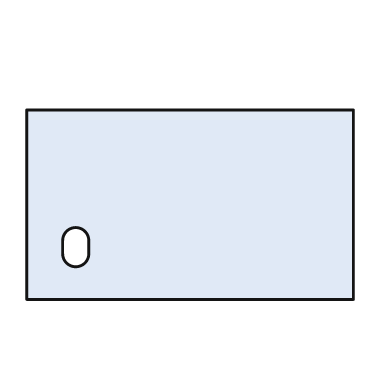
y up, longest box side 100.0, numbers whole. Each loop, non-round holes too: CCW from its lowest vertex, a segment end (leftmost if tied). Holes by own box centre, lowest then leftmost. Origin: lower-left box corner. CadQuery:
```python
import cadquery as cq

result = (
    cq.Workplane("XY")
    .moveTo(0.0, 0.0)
    .lineTo(100.0, 0.0)
    .lineTo(100.0, 58.0)
    .lineTo(0.0, 58.0)
    .close()
    .moveTo(11.0, 14.0)
    .threePointArc((15.0, 10.0), (19.0, 14.0))
    .lineTo(19.0, 18.0)
    .threePointArc((15.0, 22.0), (11.0, 18.0))
    .close()
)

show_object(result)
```